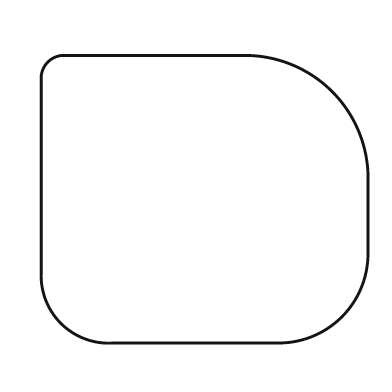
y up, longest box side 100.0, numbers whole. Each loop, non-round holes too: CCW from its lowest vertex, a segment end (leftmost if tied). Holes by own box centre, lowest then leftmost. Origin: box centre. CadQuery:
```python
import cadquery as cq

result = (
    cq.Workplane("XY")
    .moveTo(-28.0, -44.0)
    .lineTo(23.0, -44.0)
    .threePointArc((42.0, -36.0), (50.0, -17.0))
    .lineTo(50.0, 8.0)
    .threePointArc((39.0, 33.0), (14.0, 44.0))
    .lineTo(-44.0, 44.0)
    .threePointArc((-48.0, 42.0), (-50.0, 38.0))
    .lineTo(-50.0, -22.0)
    .threePointArc((-44.0, -38.0), (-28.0, -44.0))
    .close()
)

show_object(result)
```